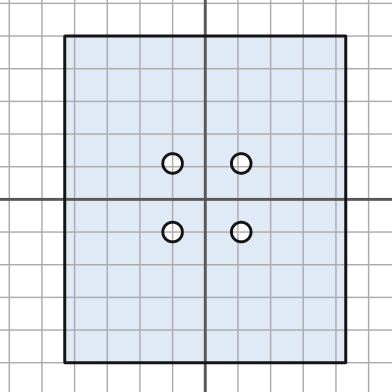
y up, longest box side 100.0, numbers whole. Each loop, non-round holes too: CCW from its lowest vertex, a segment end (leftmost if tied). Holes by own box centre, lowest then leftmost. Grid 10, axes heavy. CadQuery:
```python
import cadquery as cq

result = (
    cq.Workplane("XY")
    .moveTo(-43.0, -50.0)
    .lineTo(43.0, -50.0)
    .lineTo(43.0, 50.0)
    .lineTo(-43.0, 50.0)
    .close()
    .moveTo(-10.0, -10.0)
    .circle(3.0)
    .moveTo(11.0, -10.0)
    .circle(3.0)
    .moveTo(-10.0, 11.0)
    .circle(3.0)
    .moveTo(11.0, 11.0)
    .circle(3.0)
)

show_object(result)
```